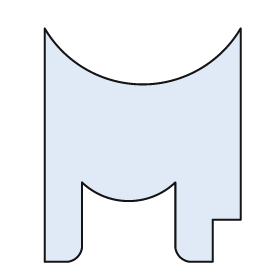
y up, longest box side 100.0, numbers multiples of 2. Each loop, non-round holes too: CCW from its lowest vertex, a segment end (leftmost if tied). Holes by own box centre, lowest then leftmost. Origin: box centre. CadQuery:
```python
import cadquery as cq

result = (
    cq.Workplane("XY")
    .moveTo(-42.0, -50.0)
    .lineTo(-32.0, -50.0)
    .threePointArc((-28.0, -48.0), (-26.0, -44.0))
    .lineTo(-26.0, -16.0)
    .threePointArc((-6.0, -24.0), (14.0, -16.0))
    .lineTo(14.0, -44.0)
    .threePointArc((16.0, -48.0), (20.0, -50.0))
    .lineTo(30.0, -50.0)
    .lineTo(30.0, -32.0)
    .lineTo(42.0, -32.0)
    .lineTo(42.0, 50.0)
    .threePointArc((0.0, 26.0), (-42.0, 50.0))
    .close()
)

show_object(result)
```